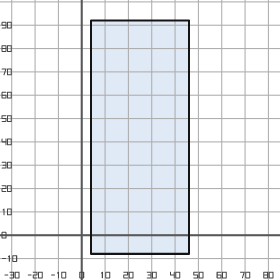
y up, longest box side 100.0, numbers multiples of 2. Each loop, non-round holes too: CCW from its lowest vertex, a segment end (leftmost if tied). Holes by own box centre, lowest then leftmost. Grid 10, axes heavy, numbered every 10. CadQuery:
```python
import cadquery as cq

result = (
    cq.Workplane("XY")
    .moveTo(4.0, -8.0)
    .lineTo(46.0, -8.0)
    .lineTo(46.0, 92.0)
    .lineTo(4.0, 92.0)
    .close()
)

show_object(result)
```